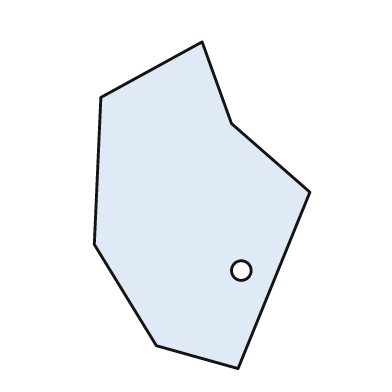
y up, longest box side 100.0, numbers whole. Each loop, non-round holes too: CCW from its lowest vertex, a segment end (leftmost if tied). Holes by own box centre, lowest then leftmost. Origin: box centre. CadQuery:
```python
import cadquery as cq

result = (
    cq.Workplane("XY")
    .moveTo(11.0, -50.0)
    .lineTo(33.0, 4.0)
    .lineTo(9.0, 25.0)
    .lineTo(0.0, 50.0)
    .lineTo(-31.0, 33.0)
    .lineTo(-33.0, -12.0)
    .lineTo(-14.0, -43.0)
    .close()
    .moveTo(12.0, -20.0)
    .circle(3.0)
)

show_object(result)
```